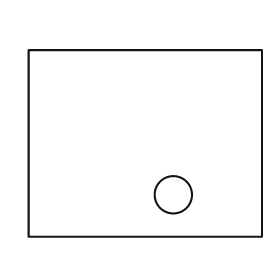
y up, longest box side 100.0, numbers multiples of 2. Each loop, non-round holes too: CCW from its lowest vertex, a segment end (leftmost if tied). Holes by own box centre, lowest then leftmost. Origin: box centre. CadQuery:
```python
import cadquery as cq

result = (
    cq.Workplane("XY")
    .moveTo(-50.0, -40.0)
    .lineTo(50.0, -40.0)
    .lineTo(50.0, 40.0)
    .lineTo(-50.0, 40.0)
    .close()
    .moveTo(12.0, -22.0)
    .circle(8.0)
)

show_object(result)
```